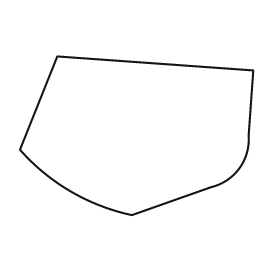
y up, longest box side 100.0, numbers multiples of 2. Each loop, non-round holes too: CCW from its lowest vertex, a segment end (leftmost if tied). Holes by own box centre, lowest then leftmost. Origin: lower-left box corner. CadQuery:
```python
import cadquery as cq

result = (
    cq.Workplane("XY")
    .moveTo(48.0, 0.0)
    .lineTo(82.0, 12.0)
    .threePointArc((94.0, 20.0), (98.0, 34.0))
    .lineTo(100.0, 62.0)
    .lineTo(16.0, 68.0)
    .lineTo(0.0, 28.0)
    .threePointArc((22.0, 10.0), (48.0, 0.0))
    .close()
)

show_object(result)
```